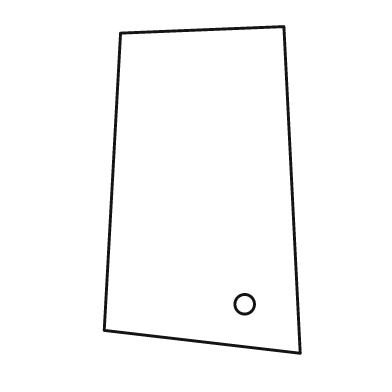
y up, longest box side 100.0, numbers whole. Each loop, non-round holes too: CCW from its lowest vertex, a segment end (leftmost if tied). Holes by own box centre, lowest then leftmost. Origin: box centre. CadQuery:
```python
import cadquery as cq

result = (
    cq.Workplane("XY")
    .moveTo(30.0, -50.0)
    .lineTo(25.0, 50.0)
    .lineTo(-25.0, 48.0)
    .lineTo(-30.0, -43.0)
    .close()
    .moveTo(13.0, -35.0)
    .circle(3.0)
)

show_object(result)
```